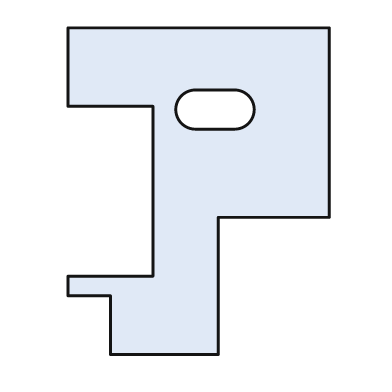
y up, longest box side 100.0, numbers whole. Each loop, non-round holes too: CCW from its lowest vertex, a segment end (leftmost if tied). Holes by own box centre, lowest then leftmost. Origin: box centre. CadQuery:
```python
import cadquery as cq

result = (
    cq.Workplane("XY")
    .moveTo(-27.0, -50.0)
    .lineTo(6.0, -50.0)
    .lineTo(6.0, -8.0)
    .lineTo(40.0, -8.0)
    .lineTo(40.0, 50.0)
    .lineTo(-40.0, 50.0)
    .lineTo(-40.0, 26.0)
    .lineTo(-14.0, 26.0)
    .lineTo(-14.0, -26.0)
    .lineTo(-40.0, -26.0)
    .lineTo(-40.0, -32.0)
    .lineTo(-27.0, -32.0)
    .close()
    .moveTo(-1.0, 19.0)
    .lineTo(11.0, 19.0)
    .threePointArc((17.0, 25.0), (11.0, 31.0))
    .lineTo(-1.0, 31.0)
    .threePointArc((-7.0, 25.0), (-1.0, 19.0))
    .close()
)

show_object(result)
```